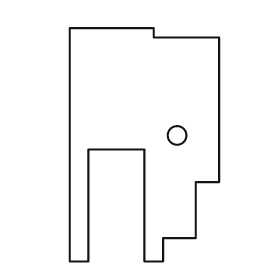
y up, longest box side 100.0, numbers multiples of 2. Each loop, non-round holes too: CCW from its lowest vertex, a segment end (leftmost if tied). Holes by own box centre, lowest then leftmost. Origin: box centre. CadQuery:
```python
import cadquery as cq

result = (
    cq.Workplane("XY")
    .moveTo(-32.0, -50.0)
    .lineTo(-24.0, -50.0)
    .lineTo(-24.0, -2.0)
    .lineTo(0.0, -2.0)
    .lineTo(0.0, -50.0)
    .lineTo(8.0, -50.0)
    .lineTo(8.0, -40.0)
    .lineTo(22.0, -40.0)
    .lineTo(22.0, -16.0)
    .lineTo(32.0, -16.0)
    .lineTo(32.0, 46.0)
    .lineTo(4.0, 46.0)
    .lineTo(4.0, 50.0)
    .lineTo(-32.0, 50.0)
    .close()
    .moveTo(14.0, 4.0)
    .circle(4.0)
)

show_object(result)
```